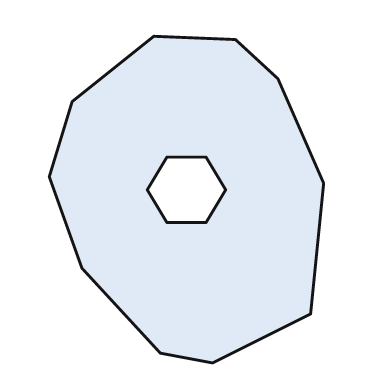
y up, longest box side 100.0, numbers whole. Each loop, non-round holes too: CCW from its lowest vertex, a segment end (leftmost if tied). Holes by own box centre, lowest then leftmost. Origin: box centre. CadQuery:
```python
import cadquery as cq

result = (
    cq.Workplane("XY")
    .moveTo(8.0, -50.0)
    .lineTo(38.0, -35.0)
    .lineTo(42.0, 5.0)
    .lineTo(28.0, 37.0)
    .lineTo(15.0, 49.0)
    .lineTo(-10.0, 50.0)
    .lineTo(-35.0, 30.0)
    .lineTo(-42.0, 7.0)
    .lineTo(-32.0, -21.0)
    .lineTo(-8.0, -47.0)
    .close()
    .moveTo(-6.0, -7.0)
    .lineTo(6.0, -7.0)
    .lineTo(12.0, 3.0)
    .lineTo(6.0, 13.0)
    .lineTo(-6.0, 13.0)
    .lineTo(-12.0, 3.0)
    .close()
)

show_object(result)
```